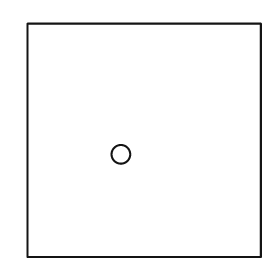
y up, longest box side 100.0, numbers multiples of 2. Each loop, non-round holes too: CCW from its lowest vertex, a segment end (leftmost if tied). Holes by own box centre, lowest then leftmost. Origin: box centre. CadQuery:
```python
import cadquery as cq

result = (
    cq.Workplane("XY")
    .moveTo(-50.0, -50.0)
    .lineTo(50.0, -50.0)
    .lineTo(50.0, 50.0)
    .lineTo(-50.0, 50.0)
    .close()
    .moveTo(-10.0, -6.0)
    .circle(4.0)
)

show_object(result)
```